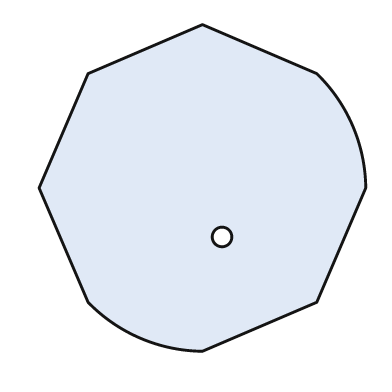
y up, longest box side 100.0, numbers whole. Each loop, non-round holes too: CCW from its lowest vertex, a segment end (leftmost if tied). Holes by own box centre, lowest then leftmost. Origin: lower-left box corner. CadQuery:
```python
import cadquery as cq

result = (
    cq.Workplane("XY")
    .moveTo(50.0, 0.0)
    .lineTo(85.0, 15.0)
    .lineTo(100.0, 50.0)
    .threePointArc((96.0, 69.0), (85.0, 85.0))
    .lineTo(50.0, 100.0)
    .lineTo(15.0, 85.0)
    .lineTo(0.0, 50.0)
    .lineTo(15.0, 15.0)
    .threePointArc((31.0, 4.0), (50.0, 0.0))
    .close()
    .moveTo(56.0, 35.0)
    .circle(3.0)
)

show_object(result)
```